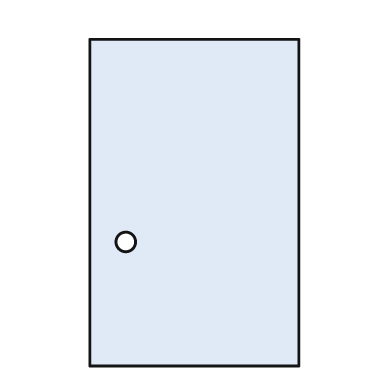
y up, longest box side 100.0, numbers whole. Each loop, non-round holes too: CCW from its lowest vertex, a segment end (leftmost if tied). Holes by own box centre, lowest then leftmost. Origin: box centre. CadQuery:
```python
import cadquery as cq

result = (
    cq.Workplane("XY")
    .moveTo(-32.0, -50.0)
    .lineTo(32.0, -50.0)
    .lineTo(32.0, 50.0)
    .lineTo(-32.0, 50.0)
    .close()
    .moveTo(-21.0, -12.0)
    .circle(3.0)
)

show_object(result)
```